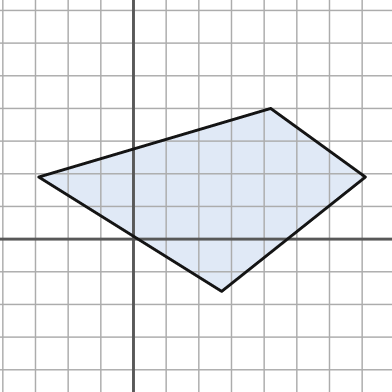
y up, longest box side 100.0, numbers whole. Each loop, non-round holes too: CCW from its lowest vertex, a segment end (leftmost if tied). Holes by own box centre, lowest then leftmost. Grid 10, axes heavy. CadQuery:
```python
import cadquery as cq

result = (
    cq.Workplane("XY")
    .moveTo(27.0, -16.0)
    .lineTo(71.0, 19.0)
    .lineTo(42.0, 40.0)
    .lineTo(-29.0, 19.0)
    .close()
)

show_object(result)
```